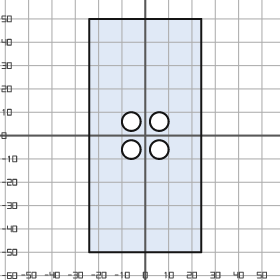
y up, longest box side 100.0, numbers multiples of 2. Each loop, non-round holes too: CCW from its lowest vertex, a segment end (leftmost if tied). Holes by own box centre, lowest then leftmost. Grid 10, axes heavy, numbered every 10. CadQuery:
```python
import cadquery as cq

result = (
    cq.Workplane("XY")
    .moveTo(-24.0, -50.0)
    .lineTo(24.0, -50.0)
    .lineTo(24.0, 50.0)
    .lineTo(-24.0, 50.0)
    .close()
    .moveTo(-6.0, -6.0)
    .circle(4.0)
    .moveTo(6.0, -6.0)
    .circle(4.0)
    .moveTo(-6.0, 6.0)
    .circle(4.0)
    .moveTo(6.0, 6.0)
    .circle(4.0)
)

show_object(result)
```